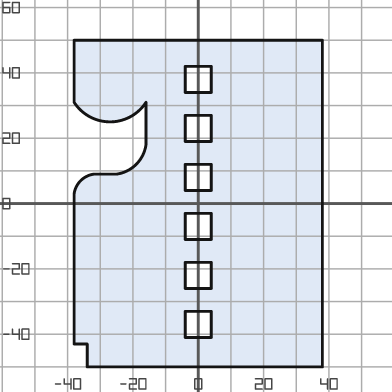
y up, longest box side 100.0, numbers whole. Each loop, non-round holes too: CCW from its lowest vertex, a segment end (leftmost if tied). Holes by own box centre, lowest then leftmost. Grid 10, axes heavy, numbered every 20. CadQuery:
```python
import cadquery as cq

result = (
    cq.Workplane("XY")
    .moveTo(-34.0, -50.0)
    .lineTo(38.0, -50.0)
    .lineTo(38.0, 50.0)
    .lineTo(-38.0, 50.0)
    .lineTo(-38.0, 31.0)
    .threePointArc((-27.0, 25.0), (-16.0, 31.0))
    .lineTo(-16.0, 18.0)
    .threePointArc((-19.0, 12.0), (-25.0, 9.0))
    .lineTo(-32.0, 9.0)
    .threePointArc((-36.0, 7.0), (-38.0, 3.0))
    .lineTo(-38.0, -43.0)
    .lineTo(-34.0, -43.0)
    .close()
    .moveTo(-4.0, -41.0)
    .lineTo(4.0, -41.0)
    .lineTo(4.0, -33.0)
    .lineTo(-4.0, -33.0)
    .close()
    .moveTo(-4.0, -26.0)
    .lineTo(4.0, -26.0)
    .lineTo(4.0, -18.0)
    .lineTo(-4.0, -18.0)
    .close()
    .moveTo(-4.0, -11.0)
    .lineTo(4.0, -11.0)
    .lineTo(4.0, -3.0)
    .lineTo(-4.0, -3.0)
    .close()
    .moveTo(-4.0, 4.0)
    .lineTo(4.0, 4.0)
    .lineTo(4.0, 12.0)
    .lineTo(-4.0, 12.0)
    .close()
    .moveTo(-4.0, 19.0)
    .lineTo(4.0, 19.0)
    .lineTo(4.0, 27.0)
    .lineTo(-4.0, 27.0)
    .close()
    .moveTo(-4.0, 34.0)
    .lineTo(4.0, 34.0)
    .lineTo(4.0, 42.0)
    .lineTo(-4.0, 42.0)
    .close()
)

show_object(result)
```